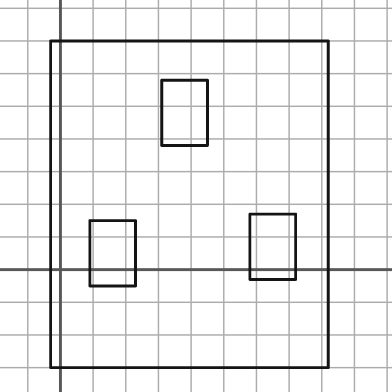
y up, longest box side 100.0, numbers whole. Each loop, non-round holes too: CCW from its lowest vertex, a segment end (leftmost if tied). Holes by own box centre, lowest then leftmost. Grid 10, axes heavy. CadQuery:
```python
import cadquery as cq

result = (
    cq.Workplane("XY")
    .moveTo(-3.0, -30.0)
    .lineTo(82.0, -30.0)
    .lineTo(82.0, 70.0)
    .lineTo(-3.0, 70.0)
    .close()
    .moveTo(9.0, -5.0)
    .lineTo(23.0, -5.0)
    .lineTo(23.0, 15.0)
    .lineTo(9.0, 15.0)
    .close()
    .moveTo(58.0, -3.0)
    .lineTo(72.0, -3.0)
    .lineTo(72.0, 17.0)
    .lineTo(58.0, 17.0)
    .close()
    .moveTo(31.0, 38.0)
    .lineTo(45.0, 38.0)
    .lineTo(45.0, 58.0)
    .lineTo(31.0, 58.0)
    .close()
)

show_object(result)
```